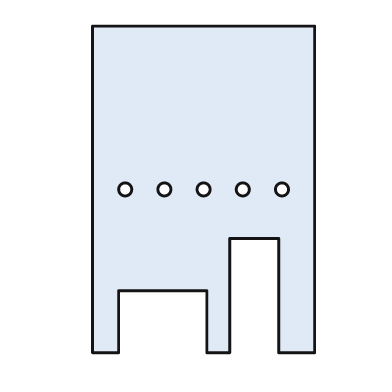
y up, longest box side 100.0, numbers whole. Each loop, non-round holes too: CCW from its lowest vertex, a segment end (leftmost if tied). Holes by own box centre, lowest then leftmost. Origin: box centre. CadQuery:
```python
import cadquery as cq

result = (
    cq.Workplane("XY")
    .moveTo(-34.0, -50.0)
    .lineTo(-26.0, -50.0)
    .lineTo(-26.0, -31.0)
    .lineTo(1.0, -31.0)
    .lineTo(1.0, -50.0)
    .lineTo(8.0, -50.0)
    .lineTo(8.0, -15.0)
    .lineTo(23.0, -15.0)
    .lineTo(23.0, -50.0)
    .lineTo(34.0, -50.0)
    .lineTo(34.0, 50.0)
    .lineTo(-34.0, 50.0)
    .close()
    .moveTo(-24.0, 0.0)
    .circle(2.0)
    .moveTo(-12.0, 0.0)
    .circle(2.0)
    .moveTo(0.0, 0.0)
    .circle(2.0)
    .moveTo(12.0, 0.0)
    .circle(2.0)
    .moveTo(24.0, 0.0)
    .circle(2.0)
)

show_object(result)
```